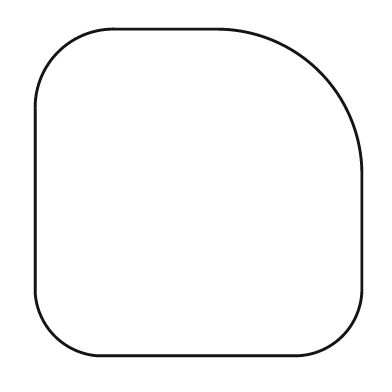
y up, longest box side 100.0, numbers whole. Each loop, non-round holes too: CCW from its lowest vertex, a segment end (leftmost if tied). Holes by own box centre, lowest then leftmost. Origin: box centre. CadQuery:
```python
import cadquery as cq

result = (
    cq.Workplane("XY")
    .moveTo(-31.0, -50.0)
    .lineTo(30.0, -50.0)
    .threePointArc((44.0, -44.0), (50.0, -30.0))
    .lineTo(50.0, 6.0)
    .threePointArc((37.0, 37.0), (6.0, 50.0))
    .lineTo(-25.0, 50.0)
    .threePointArc((-43.0, 43.0), (-50.0, 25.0))
    .lineTo(-50.0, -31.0)
    .threePointArc((-44.0, -44.0), (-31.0, -50.0))
    .close()
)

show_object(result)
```